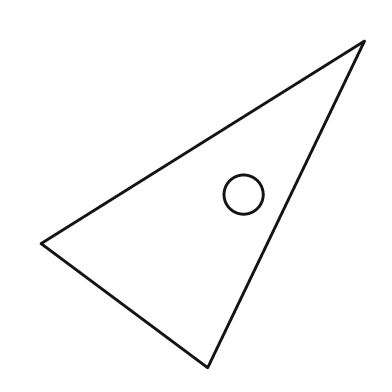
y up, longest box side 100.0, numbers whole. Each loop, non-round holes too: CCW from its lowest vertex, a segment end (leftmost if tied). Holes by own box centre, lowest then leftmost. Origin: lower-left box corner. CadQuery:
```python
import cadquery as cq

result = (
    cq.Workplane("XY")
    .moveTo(51.0, 0.0)
    .lineTo(99.0, 100.0)
    .lineTo(0.0, 38.0)
    .close()
    .moveTo(62.0, 53.0)
    .circle(6.0)
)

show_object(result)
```